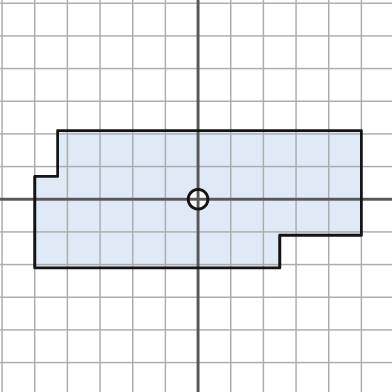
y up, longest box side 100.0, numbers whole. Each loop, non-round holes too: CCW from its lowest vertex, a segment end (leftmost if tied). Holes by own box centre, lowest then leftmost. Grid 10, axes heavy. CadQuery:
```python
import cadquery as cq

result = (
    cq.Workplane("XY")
    .moveTo(-50.0, -21.0)
    .lineTo(25.0, -21.0)
    .lineTo(25.0, -11.0)
    .lineTo(50.0, -11.0)
    .lineTo(50.0, 21.0)
    .lineTo(-43.0, 21.0)
    .lineTo(-43.0, 7.0)
    .lineTo(-50.0, 7.0)
    .close()
    .moveTo(0.0, 0.0)
    .circle(3.0)
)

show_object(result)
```